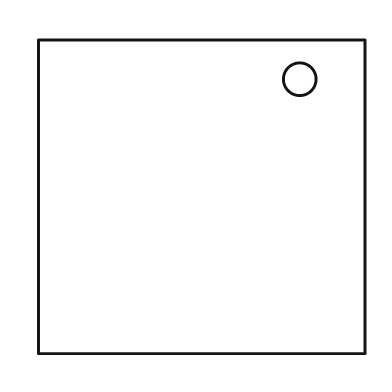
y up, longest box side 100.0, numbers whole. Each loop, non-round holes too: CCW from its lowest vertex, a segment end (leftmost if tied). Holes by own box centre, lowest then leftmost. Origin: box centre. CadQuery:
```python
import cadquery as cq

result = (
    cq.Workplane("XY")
    .moveTo(-50.0, -48.0)
    .lineTo(50.0, -48.0)
    .lineTo(50.0, 48.0)
    .lineTo(-50.0, 48.0)
    .close()
    .moveTo(30.0, 36.0)
    .circle(5.0)
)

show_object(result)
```